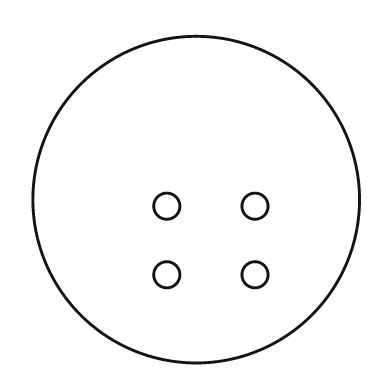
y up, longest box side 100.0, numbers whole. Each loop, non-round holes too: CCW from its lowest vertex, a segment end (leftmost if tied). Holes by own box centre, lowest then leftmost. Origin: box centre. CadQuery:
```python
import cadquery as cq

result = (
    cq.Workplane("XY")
    .moveTo(0.0, 0.0)
    .circle(50.0)
    .moveTo(-9.0, -23.0)
    .circle(4.0)
    .moveTo(18.0, -23.0)
    .circle(4.0)
    .moveTo(-9.0, -2.0)
    .circle(4.0)
    .moveTo(18.0, -2.0)
    .circle(4.0)
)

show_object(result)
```